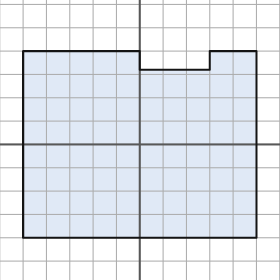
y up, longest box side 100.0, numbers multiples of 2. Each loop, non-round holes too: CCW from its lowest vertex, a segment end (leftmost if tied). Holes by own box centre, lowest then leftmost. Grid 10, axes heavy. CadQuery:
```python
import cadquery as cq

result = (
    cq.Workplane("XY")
    .moveTo(-50.0, -40.0)
    .lineTo(50.0, -40.0)
    .lineTo(50.0, 40.0)
    .lineTo(30.0, 40.0)
    .lineTo(30.0, 32.0)
    .lineTo(0.0, 32.0)
    .lineTo(0.0, 40.0)
    .lineTo(-50.0, 40.0)
    .close()
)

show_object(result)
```